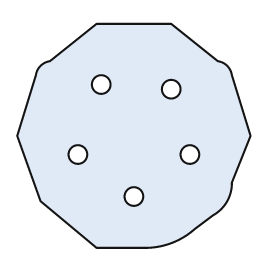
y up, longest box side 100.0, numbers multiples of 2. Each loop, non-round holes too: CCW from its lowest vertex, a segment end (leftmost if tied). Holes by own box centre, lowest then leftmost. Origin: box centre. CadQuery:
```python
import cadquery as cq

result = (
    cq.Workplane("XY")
    .moveTo(-16.0, -48.0)
    .lineTo(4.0, -48.0)
    .threePointArc((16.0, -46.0), (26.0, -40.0))
    .lineTo(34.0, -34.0)
    .threePointArc((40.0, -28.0), (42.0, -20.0))
    .lineTo(50.0, 0.0)
    .lineTo(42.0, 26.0)
    .threePointArc((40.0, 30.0), (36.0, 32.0))
    .lineTo(16.0, 48.0)
    .lineTo(-16.0, 48.0)
    .lineTo(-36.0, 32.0)
    .threePointArc((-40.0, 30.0), (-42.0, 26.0))
    .lineTo(-50.0, 0.0)
    .lineTo(-40.0, -28.0)
    .close()
    .moveTo(0.0, -26.0)
    .circle(4.0)
    .moveTo(-24.0, -8.0)
    .circle(4.0)
    .moveTo(24.0, -8.0)
    .circle(4.0)
    .moveTo(16.0, 20.0)
    .circle(4.0)
    .moveTo(-14.0, 22.0)
    .circle(4.0)
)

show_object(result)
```